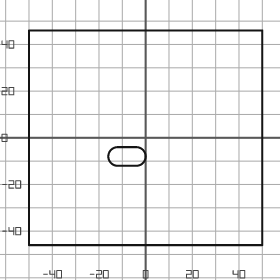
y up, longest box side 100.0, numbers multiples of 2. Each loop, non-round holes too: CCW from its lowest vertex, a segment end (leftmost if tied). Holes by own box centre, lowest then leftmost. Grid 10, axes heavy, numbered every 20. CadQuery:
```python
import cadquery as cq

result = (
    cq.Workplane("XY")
    .moveTo(-50.0, -46.0)
    .lineTo(50.0, -46.0)
    .lineTo(50.0, 46.0)
    .lineTo(-50.0, 46.0)
    .close()
    .moveTo(-12.0, -12.0)
    .lineTo(-4.0, -12.0)
    .threePointArc((0.0, -8.0), (-4.0, -4.0))
    .lineTo(-12.0, -4.0)
    .threePointArc((-16.0, -8.0), (-12.0, -12.0))
    .close()
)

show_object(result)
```